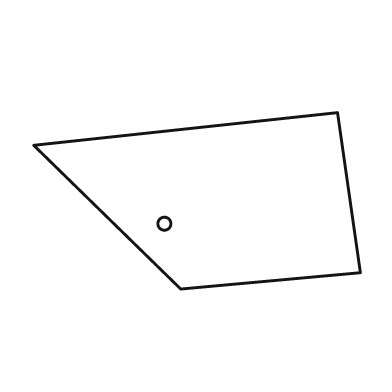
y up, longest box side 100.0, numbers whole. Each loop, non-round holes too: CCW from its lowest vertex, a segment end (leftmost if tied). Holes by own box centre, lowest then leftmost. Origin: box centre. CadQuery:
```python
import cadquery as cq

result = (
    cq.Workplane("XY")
    .moveTo(-5.0, -27.0)
    .lineTo(50.0, -22.0)
    .lineTo(43.0, 27.0)
    .lineTo(-50.0, 17.0)
    .close()
    .moveTo(-10.0, -7.0)
    .circle(2.0)
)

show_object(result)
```